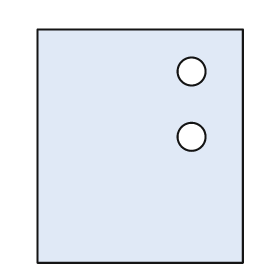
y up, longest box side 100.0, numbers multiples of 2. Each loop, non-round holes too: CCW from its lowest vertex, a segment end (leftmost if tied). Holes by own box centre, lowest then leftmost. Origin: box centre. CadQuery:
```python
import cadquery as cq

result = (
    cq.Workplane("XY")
    .moveTo(-44.0, -50.0)
    .lineTo(44.0, -50.0)
    .lineTo(44.0, 50.0)
    .lineTo(-44.0, 50.0)
    .close()
    .moveTo(22.0, 4.0)
    .circle(6.0)
    .moveTo(22.0, 32.0)
    .circle(6.0)
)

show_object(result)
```